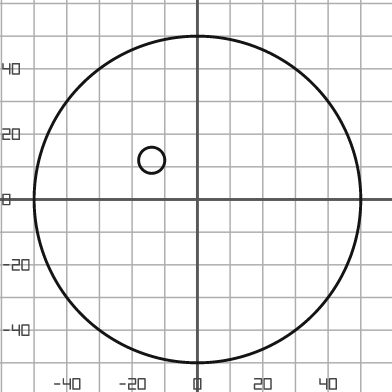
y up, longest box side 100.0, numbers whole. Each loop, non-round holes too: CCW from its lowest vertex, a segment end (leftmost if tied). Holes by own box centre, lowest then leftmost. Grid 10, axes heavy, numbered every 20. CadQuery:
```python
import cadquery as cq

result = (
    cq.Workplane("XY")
    .moveTo(0.0, 0.0)
    .circle(50.0)
    .moveTo(-14.0, 12.0)
    .circle(4.0)
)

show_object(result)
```